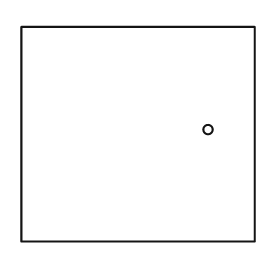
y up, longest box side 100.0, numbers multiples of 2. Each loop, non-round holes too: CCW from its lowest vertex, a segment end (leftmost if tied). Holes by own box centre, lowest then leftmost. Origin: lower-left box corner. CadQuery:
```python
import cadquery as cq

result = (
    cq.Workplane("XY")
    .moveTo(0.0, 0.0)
    .lineTo(100.0, 0.0)
    .lineTo(100.0, 92.0)
    .lineTo(0.0, 92.0)
    .close()
    .moveTo(80.0, 48.0)
    .circle(2.0)
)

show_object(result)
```